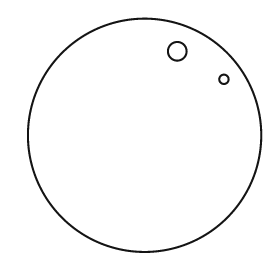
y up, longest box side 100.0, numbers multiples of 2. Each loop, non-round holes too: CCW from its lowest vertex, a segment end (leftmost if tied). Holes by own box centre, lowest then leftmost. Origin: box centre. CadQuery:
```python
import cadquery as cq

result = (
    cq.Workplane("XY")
    .moveTo(0.0, 0.0)
    .circle(50.0)
    .moveTo(34.0, 24.0)
    .circle(2.0)
    .moveTo(14.0, 36.0)
    .circle(4.0)
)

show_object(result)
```